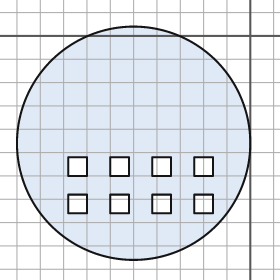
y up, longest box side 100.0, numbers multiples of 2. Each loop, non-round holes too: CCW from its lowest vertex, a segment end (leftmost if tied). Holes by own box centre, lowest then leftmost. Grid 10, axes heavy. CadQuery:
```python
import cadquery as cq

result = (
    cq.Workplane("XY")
    .moveTo(-50.0, -46.0)
    .circle(50.0)
    .moveTo(-78.0, -76.0)
    .lineTo(-70.0, -76.0)
    .lineTo(-70.0, -68.0)
    .lineTo(-78.0, -68.0)
    .close()
    .moveTo(-60.0, -76.0)
    .lineTo(-52.0, -76.0)
    .lineTo(-52.0, -68.0)
    .lineTo(-60.0, -68.0)
    .close()
    .moveTo(-42.0, -76.0)
    .lineTo(-34.0, -76.0)
    .lineTo(-34.0, -68.0)
    .lineTo(-42.0, -68.0)
    .close()
    .moveTo(-24.0, -76.0)
    .lineTo(-16.0, -76.0)
    .lineTo(-16.0, -68.0)
    .lineTo(-24.0, -68.0)
    .close()
    .moveTo(-78.0, -60.0)
    .lineTo(-70.0, -60.0)
    .lineTo(-70.0, -52.0)
    .lineTo(-78.0, -52.0)
    .close()
    .moveTo(-60.0, -60.0)
    .lineTo(-52.0, -60.0)
    .lineTo(-52.0, -52.0)
    .lineTo(-60.0, -52.0)
    .close()
    .moveTo(-42.0, -60.0)
    .lineTo(-34.0, -60.0)
    .lineTo(-34.0, -52.0)
    .lineTo(-42.0, -52.0)
    .close()
    .moveTo(-24.0, -60.0)
    .lineTo(-16.0, -60.0)
    .lineTo(-16.0, -52.0)
    .lineTo(-24.0, -52.0)
    .close()
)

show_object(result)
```